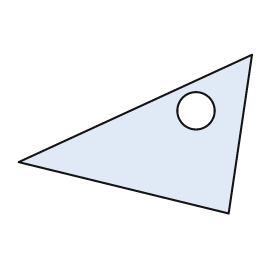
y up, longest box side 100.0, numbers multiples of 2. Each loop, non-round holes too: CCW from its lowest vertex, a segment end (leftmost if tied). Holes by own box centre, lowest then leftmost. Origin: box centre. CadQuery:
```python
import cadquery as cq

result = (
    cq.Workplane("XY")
    .moveTo(40.0, -34.0)
    .lineTo(50.0, 34.0)
    .lineTo(-50.0, -12.0)
    .close()
    .moveTo(26.0, 10.0)
    .circle(8.0)
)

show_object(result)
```